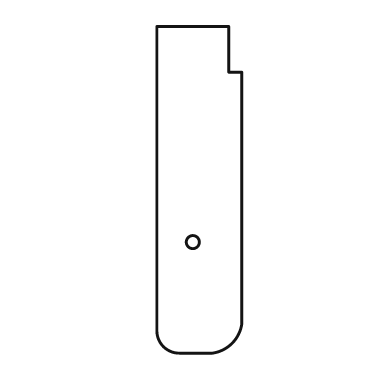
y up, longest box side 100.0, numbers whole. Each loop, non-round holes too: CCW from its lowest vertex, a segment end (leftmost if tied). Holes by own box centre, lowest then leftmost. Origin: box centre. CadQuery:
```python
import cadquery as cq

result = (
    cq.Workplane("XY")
    .moveTo(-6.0, -50.0)
    .lineTo(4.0, -50.0)
    .threePointArc((10.0, -47.0), (13.0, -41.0))
    .lineTo(13.0, 36.0)
    .lineTo(9.0, 36.0)
    .lineTo(9.0, 50.0)
    .lineTo(-13.0, 50.0)
    .lineTo(-13.0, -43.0)
    .threePointArc((-11.0, -48.0), (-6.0, -50.0))
    .close()
    .moveTo(-2.0, -16.0)
    .circle(2.0)
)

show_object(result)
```